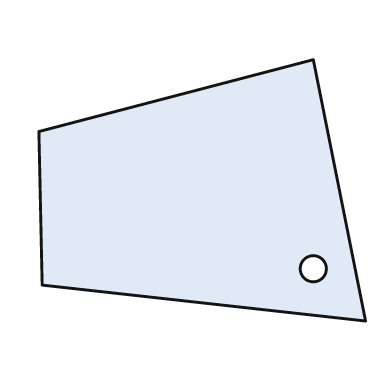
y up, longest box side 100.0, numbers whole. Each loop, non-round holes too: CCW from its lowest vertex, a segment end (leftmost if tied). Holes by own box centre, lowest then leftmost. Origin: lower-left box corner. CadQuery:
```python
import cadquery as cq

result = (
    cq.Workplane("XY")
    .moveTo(100.0, 0.0)
    .lineTo(84.0, 80.0)
    .lineTo(0.0, 58.0)
    .lineTo(1.0, 11.0)
    .close()
    .moveTo(84.0, 16.0)
    .circle(4.0)
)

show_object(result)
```